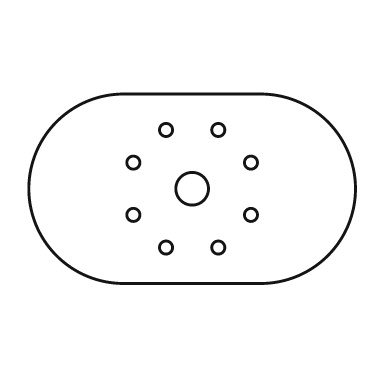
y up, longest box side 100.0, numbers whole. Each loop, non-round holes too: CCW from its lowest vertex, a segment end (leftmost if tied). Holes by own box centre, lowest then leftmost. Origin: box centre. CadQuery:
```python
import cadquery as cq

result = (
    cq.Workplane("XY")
    .moveTo(-21.0, -29.0)
    .lineTo(21.0, -29.0)
    .threePointArc((50.0, 0.0), (21.0, 29.0))
    .lineTo(-21.0, 29.0)
    .threePointArc((-50.0, 0.0), (-21.0, -29.0))
    .close()
    .moveTo(-8.0, -18.0)
    .circle(2.0)
    .moveTo(8.0, -18.0)
    .circle(2.0)
    .moveTo(-18.0, -8.0)
    .circle(2.0)
    .moveTo(18.0, -8.0)
    .circle(2.0)
    .moveTo(0.0, 0.0)
    .circle(5.0)
    .moveTo(-18.0, 8.0)
    .circle(2.0)
    .moveTo(18.0, 8.0)
    .circle(2.0)
    .moveTo(-8.0, 18.0)
    .circle(2.0)
    .moveTo(8.0, 18.0)
    .circle(2.0)
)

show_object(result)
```